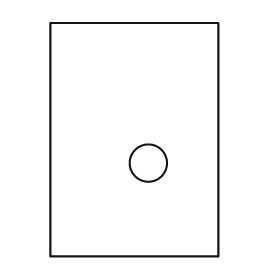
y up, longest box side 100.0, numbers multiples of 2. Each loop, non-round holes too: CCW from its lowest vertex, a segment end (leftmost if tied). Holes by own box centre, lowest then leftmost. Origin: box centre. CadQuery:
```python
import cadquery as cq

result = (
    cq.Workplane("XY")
    .moveTo(-36.0, -50.0)
    .lineTo(36.0, -50.0)
    .lineTo(36.0, 50.0)
    .lineTo(-36.0, 50.0)
    .close()
    .moveTo(6.0, -10.0)
    .circle(8.0)
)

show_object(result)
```